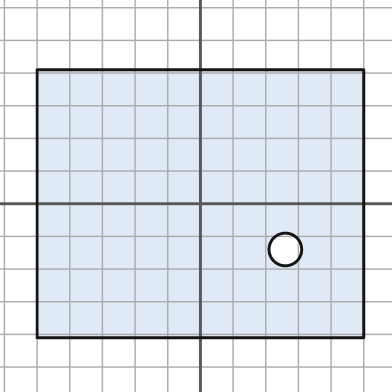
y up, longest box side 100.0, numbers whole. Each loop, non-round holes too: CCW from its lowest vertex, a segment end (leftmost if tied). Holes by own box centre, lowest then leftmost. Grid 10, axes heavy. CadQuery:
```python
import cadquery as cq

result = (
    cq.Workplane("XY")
    .moveTo(-50.0, -41.0)
    .lineTo(50.0, -41.0)
    .lineTo(50.0, 41.0)
    .lineTo(-50.0, 41.0)
    .close()
    .moveTo(26.0, -14.0)
    .circle(5.0)
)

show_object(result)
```